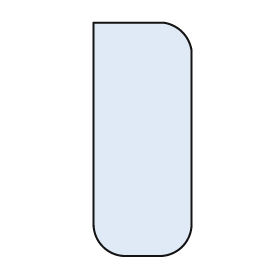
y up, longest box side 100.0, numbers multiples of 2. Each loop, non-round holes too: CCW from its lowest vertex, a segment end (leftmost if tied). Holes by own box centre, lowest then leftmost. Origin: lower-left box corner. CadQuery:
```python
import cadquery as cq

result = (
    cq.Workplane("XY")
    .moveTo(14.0, 0.0)
    .lineTo(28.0, 0.0)
    .threePointArc((38.0, 4.0), (42.0, 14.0))
    .lineTo(42.0, 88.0)
    .threePointArc((38.0, 96.0), (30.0, 100.0))
    .lineTo(0.0, 100.0)
    .lineTo(0.0, 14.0)
    .threePointArc((4.0, 4.0), (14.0, 0.0))
    .close()
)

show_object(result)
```